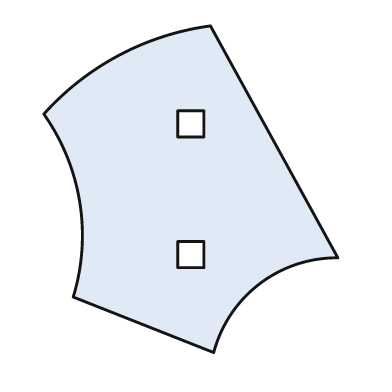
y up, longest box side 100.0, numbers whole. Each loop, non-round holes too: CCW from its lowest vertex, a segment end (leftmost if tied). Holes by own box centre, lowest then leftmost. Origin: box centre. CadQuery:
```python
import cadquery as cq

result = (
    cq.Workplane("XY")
    .moveTo(7.0, -50.0)
    .threePointArc((21.0, -29.0), (45.0, -21.0))
    .lineTo(6.0, 50.0)
    .threePointArc((-22.0, 41.0), (-45.0, 23.0))
    .threePointArc((-34.0, -4.0), (-36.0, -33.0))
    .close()
    .moveTo(-4.0, -24.0)
    .lineTo(4.0, -24.0)
    .lineTo(4.0, -16.0)
    .lineTo(-4.0, -16.0)
    .close()
    .moveTo(-4.0, 16.0)
    .lineTo(4.0, 16.0)
    .lineTo(4.0, 24.0)
    .lineTo(-4.0, 24.0)
    .close()
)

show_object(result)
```